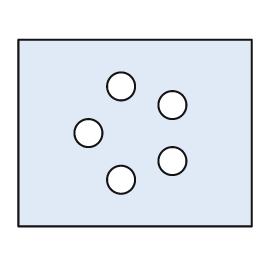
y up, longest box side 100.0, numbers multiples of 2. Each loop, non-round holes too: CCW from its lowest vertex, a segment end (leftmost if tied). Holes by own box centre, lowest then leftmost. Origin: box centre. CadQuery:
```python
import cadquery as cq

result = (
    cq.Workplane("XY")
    .moveTo(-50.0, -40.0)
    .lineTo(50.0, -40.0)
    .lineTo(50.0, 40.0)
    .lineTo(-50.0, 40.0)
    .close()
    .moveTo(-6.0, -20.0)
    .circle(6.0)
    .moveTo(16.0, -12.0)
    .circle(6.0)
    .moveTo(-20.0, 0.0)
    .circle(6.0)
    .moveTo(16.0, 12.0)
    .circle(6.0)
    .moveTo(-6.0, 20.0)
    .circle(6.0)
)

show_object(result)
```